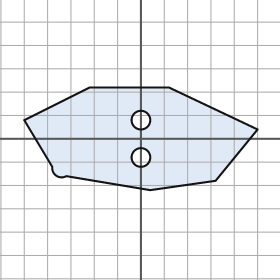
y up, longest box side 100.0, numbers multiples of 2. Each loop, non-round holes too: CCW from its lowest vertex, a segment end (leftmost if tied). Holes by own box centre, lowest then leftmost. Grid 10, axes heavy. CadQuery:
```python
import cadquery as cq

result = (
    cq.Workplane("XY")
    .moveTo(4.0, -22.0)
    .lineTo(32.0, -18.0)
    .lineTo(50.0, 4.0)
    .lineTo(12.0, 22.0)
    .lineTo(-22.0, 22.0)
    .lineTo(-50.0, 8.0)
    .lineTo(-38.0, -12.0)
    .threePointArc((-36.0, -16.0), (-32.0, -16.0))
    .close()
    .moveTo(0.0, -8.0)
    .circle(4.0)
    .moveTo(0.0, 8.0)
    .circle(4.0)
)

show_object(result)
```